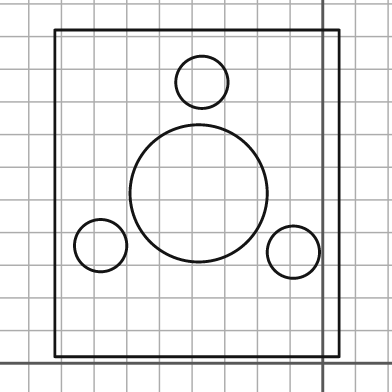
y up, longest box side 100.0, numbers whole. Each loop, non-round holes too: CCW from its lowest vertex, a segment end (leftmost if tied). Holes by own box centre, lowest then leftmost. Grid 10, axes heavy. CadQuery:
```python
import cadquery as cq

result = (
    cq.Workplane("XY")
    .moveTo(-82.0, 2.0)
    .lineTo(5.0, 2.0)
    .lineTo(5.0, 102.0)
    .lineTo(-82.0, 102.0)
    .close()
    .moveTo(-9.0, 34.0)
    .circle(8.0)
    .moveTo(-68.0, 36.0)
    .circle(8.0)
    .moveTo(-38.0, 52.0)
    .circle(21.0)
    .moveTo(-37.0, 86.0)
    .circle(8.0)
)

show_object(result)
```